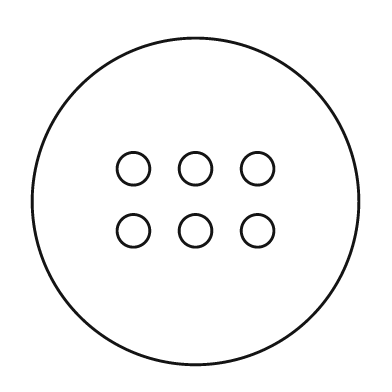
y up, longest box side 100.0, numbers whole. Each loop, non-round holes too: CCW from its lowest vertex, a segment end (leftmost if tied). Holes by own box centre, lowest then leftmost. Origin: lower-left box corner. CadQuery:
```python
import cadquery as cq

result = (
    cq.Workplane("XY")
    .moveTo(50.0, 50.0)
    .circle(50.0)
    .moveTo(31.0, 41.0)
    .circle(5.0)
    .moveTo(50.0, 41.0)
    .circle(5.0)
    .moveTo(69.0, 41.0)
    .circle(5.0)
    .moveTo(31.0, 60.0)
    .circle(5.0)
    .moveTo(50.0, 60.0)
    .circle(5.0)
    .moveTo(69.0, 60.0)
    .circle(5.0)
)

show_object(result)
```